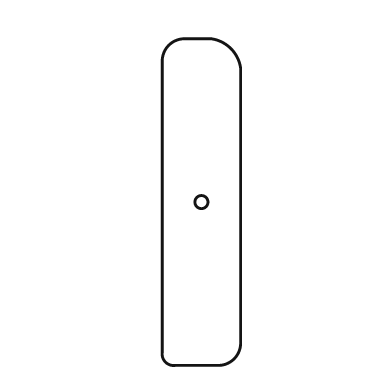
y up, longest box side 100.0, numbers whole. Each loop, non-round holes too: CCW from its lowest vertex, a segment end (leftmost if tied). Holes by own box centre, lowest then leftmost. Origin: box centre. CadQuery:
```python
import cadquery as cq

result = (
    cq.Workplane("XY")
    .moveTo(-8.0, -50.0)
    .lineTo(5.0, -50.0)
    .threePointArc((10.0, -48.0), (12.0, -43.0))
    .lineTo(12.0, 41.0)
    .threePointArc((9.0, 47.0), (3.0, 50.0))
    .lineTo(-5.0, 50.0)
    .threePointArc((-10.0, 48.0), (-12.0, 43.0))
    .lineTo(-12.0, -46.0)
    .threePointArc((-11.0, -49.0), (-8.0, -50.0))
    .close()
    .moveTo(0.0, 0.0)
    .circle(2.0)
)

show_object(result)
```